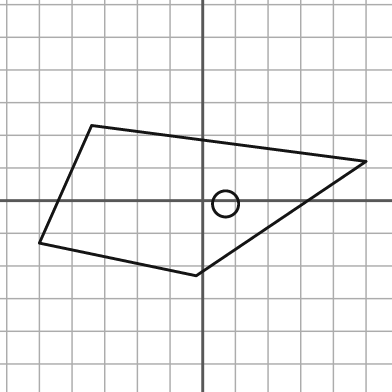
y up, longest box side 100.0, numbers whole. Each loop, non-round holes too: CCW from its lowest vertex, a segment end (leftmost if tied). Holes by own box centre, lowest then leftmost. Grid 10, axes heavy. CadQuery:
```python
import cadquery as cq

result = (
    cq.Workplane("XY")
    .moveTo(-2.0, -23.0)
    .lineTo(50.0, 12.0)
    .lineTo(-34.0, 23.0)
    .lineTo(-50.0, -13.0)
    .close()
    .moveTo(7.0, -1.0)
    .circle(4.0)
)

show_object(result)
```